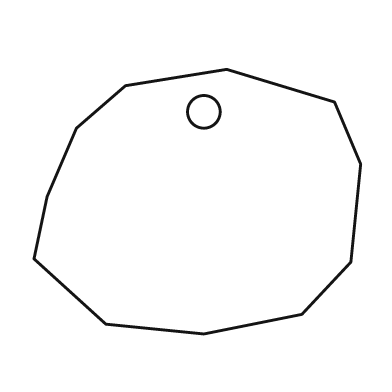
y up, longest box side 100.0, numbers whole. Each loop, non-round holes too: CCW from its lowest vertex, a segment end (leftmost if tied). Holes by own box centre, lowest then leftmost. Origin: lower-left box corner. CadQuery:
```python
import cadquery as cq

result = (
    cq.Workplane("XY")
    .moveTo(52.0, 0.0)
    .lineTo(82.0, 6.0)
    .lineTo(97.0, 22.0)
    .lineTo(100.0, 52.0)
    .lineTo(92.0, 71.0)
    .lineTo(59.0, 81.0)
    .lineTo(28.0, 76.0)
    .lineTo(13.0, 63.0)
    .lineTo(4.0, 42.0)
    .lineTo(0.0, 23.0)
    .lineTo(22.0, 3.0)
    .close()
    .moveTo(52.0, 68.0)
    .circle(5.0)
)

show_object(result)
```